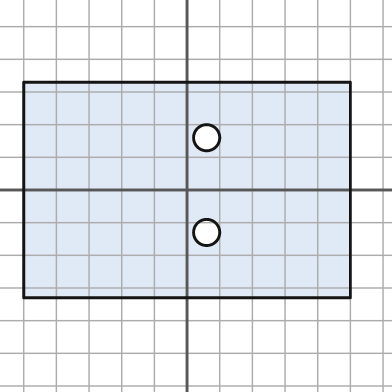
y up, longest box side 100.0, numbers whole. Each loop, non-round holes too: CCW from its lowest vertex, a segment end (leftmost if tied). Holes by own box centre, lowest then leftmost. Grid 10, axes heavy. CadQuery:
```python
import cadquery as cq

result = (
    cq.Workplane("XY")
    .moveTo(-50.0, -33.0)
    .lineTo(50.0, -33.0)
    .lineTo(50.0, 33.0)
    .lineTo(-50.0, 33.0)
    .close()
    .moveTo(6.0, -13.0)
    .circle(4.0)
    .moveTo(6.0, 16.0)
    .circle(4.0)
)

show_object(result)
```